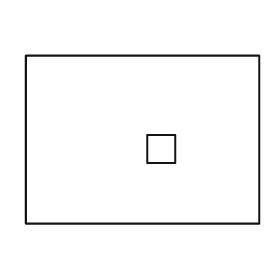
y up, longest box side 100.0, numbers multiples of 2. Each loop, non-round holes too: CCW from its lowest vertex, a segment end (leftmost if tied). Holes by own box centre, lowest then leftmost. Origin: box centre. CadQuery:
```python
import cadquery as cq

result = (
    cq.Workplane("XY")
    .moveTo(-50.0, -36.0)
    .lineTo(50.0, -36.0)
    .lineTo(50.0, 36.0)
    .lineTo(-50.0, 36.0)
    .close()
    .moveTo(2.0, -10.0)
    .lineTo(14.0, -10.0)
    .lineTo(14.0, 2.0)
    .lineTo(2.0, 2.0)
    .close()
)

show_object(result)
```